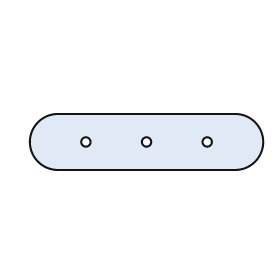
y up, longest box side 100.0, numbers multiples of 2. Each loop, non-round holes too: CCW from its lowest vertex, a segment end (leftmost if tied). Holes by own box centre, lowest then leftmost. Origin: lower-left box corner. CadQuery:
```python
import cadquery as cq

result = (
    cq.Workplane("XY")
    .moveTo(12.0, 0.0)
    .lineTo(88.0, 0.0)
    .threePointArc((100.0, 12.0), (88.0, 24.0))
    .lineTo(12.0, 24.0)
    .threePointArc((0.0, 12.0), (12.0, 0.0))
    .close()
    .moveTo(24.0, 12.0)
    .circle(2.0)
    .moveTo(50.0, 12.0)
    .circle(2.0)
    .moveTo(76.0, 12.0)
    .circle(2.0)
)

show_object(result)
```